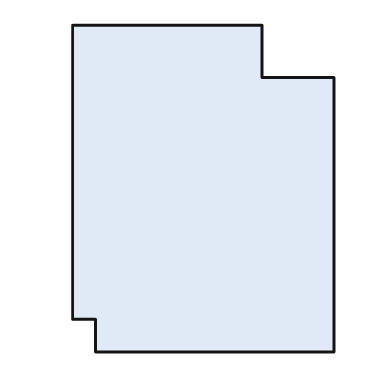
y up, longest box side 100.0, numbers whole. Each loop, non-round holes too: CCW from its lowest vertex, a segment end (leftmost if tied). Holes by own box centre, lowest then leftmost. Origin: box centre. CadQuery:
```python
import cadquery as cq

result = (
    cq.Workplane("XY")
    .moveTo(-33.0, -50.0)
    .lineTo(40.0, -50.0)
    .lineTo(40.0, 34.0)
    .lineTo(18.0, 34.0)
    .lineTo(18.0, 50.0)
    .lineTo(-40.0, 50.0)
    .lineTo(-40.0, -40.0)
    .lineTo(-33.0, -40.0)
    .close()
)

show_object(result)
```